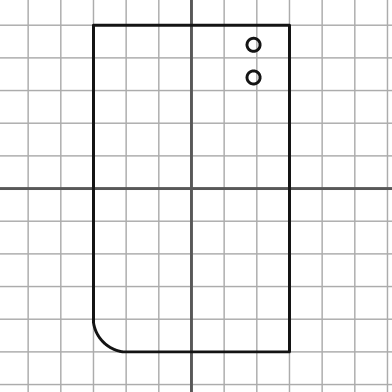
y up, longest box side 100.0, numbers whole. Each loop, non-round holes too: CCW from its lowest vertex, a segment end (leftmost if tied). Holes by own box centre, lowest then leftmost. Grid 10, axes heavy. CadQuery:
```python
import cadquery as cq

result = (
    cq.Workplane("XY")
    .moveTo(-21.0, -50.0)
    .lineTo(30.0, -50.0)
    .lineTo(30.0, 50.0)
    .lineTo(-30.0, 50.0)
    .lineTo(-30.0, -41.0)
    .threePointArc((-27.0, -47.0), (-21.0, -50.0))
    .close()
    .moveTo(19.0, 34.0)
    .circle(2.0)
    .moveTo(19.0, 44.0)
    .circle(2.0)
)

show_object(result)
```